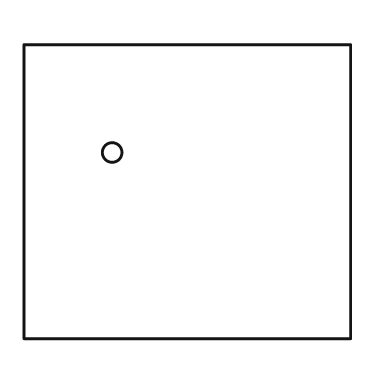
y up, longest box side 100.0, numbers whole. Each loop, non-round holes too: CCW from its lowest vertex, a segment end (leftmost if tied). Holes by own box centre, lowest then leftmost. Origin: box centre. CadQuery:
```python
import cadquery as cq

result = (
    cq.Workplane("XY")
    .moveTo(-50.0, -45.0)
    .lineTo(50.0, -45.0)
    .lineTo(50.0, 45.0)
    .lineTo(-50.0, 45.0)
    .close()
    .moveTo(-23.0, 12.0)
    .circle(3.0)
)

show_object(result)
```